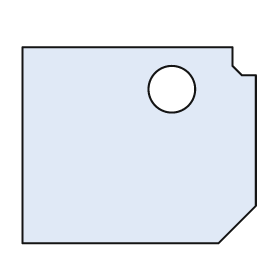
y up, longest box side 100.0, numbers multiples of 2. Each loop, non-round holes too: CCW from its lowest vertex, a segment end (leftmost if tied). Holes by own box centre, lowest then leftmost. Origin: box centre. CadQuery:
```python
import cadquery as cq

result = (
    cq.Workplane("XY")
    .moveTo(-50.0, -42.0)
    .lineTo(34.0, -42.0)
    .lineTo(50.0, -26.0)
    .lineTo(50.0, 30.0)
    .lineTo(44.0, 30.0)
    .lineTo(40.0, 34.0)
    .lineTo(40.0, 42.0)
    .lineTo(-50.0, 42.0)
    .close()
    .moveTo(14.0, 24.0)
    .circle(10.0)
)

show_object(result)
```